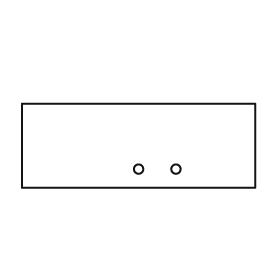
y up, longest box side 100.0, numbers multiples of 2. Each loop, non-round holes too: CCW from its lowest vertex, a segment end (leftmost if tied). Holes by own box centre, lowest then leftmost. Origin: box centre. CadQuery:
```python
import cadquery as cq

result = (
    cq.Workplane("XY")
    .moveTo(-50.0, -18.0)
    .lineTo(50.0, -18.0)
    .lineTo(50.0, 18.0)
    .lineTo(-50.0, 18.0)
    .close()
    .moveTo(0.0, -10.0)
    .circle(2.0)
    .moveTo(16.0, -10.0)
    .circle(2.0)
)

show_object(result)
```